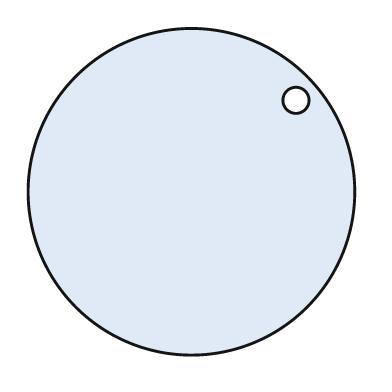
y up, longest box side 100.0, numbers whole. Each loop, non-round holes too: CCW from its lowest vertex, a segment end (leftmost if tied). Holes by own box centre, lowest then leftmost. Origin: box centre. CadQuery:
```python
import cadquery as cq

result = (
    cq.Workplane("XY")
    .moveTo(0.0, 0.0)
    .circle(50.0)
    .moveTo(32.0, 28.0)
    .circle(4.0)
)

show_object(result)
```